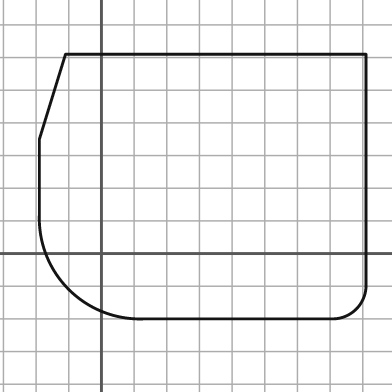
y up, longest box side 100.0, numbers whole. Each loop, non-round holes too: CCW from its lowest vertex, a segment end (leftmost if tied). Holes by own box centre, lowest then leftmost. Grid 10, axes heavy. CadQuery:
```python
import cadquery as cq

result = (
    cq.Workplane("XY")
    .moveTo(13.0, -20.0)
    .lineTo(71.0, -20.0)
    .threePointArc((78.0, -17.0), (81.0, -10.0))
    .lineTo(81.0, 61.0)
    .lineTo(-11.0, 61.0)
    .lineTo(-19.0, 35.0)
    .lineTo(-19.0, 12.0)
    .threePointArc((-10.0, -11.0), (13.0, -20.0))
    .close()
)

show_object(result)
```